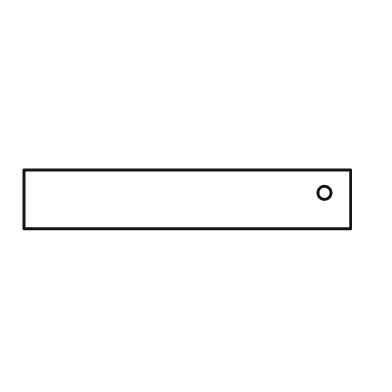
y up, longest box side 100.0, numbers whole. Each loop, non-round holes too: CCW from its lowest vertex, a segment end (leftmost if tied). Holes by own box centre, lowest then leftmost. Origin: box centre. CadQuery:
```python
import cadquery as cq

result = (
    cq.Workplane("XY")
    .moveTo(-50.0, -9.0)
    .lineTo(50.0, -9.0)
    .lineTo(50.0, 9.0)
    .lineTo(-50.0, 9.0)
    .close()
    .moveTo(42.0, 2.0)
    .circle(2.0)
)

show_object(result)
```